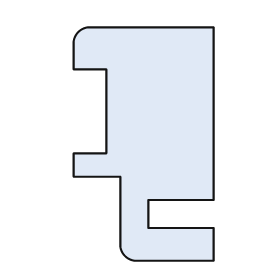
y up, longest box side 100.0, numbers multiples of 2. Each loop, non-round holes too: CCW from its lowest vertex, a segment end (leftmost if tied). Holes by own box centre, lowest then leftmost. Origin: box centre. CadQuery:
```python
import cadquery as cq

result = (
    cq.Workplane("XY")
    .moveTo(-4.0, -50.0)
    .lineTo(30.0, -50.0)
    .lineTo(30.0, -36.0)
    .lineTo(2.0, -36.0)
    .lineTo(2.0, -24.0)
    .lineTo(30.0, -24.0)
    .lineTo(30.0, 50.0)
    .lineTo(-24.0, 50.0)
    .threePointArc((-28.0, 48.0), (-30.0, 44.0))
    .lineTo(-30.0, 32.0)
    .lineTo(-16.0, 32.0)
    .lineTo(-16.0, -4.0)
    .lineTo(-30.0, -4.0)
    .lineTo(-30.0, -14.0)
    .lineTo(-10.0, -14.0)
    .lineTo(-10.0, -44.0)
    .threePointArc((-8.0, -48.0), (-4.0, -50.0))
    .close()
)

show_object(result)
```